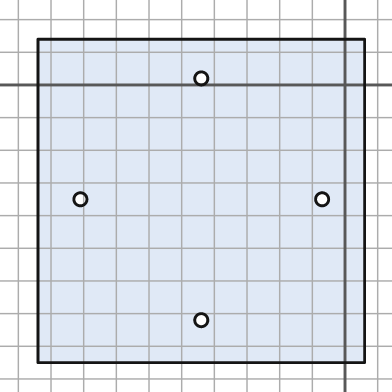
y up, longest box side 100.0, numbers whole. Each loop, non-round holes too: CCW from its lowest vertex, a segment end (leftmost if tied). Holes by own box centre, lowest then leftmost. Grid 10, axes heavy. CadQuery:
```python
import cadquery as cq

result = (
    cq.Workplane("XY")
    .moveTo(-94.0, -85.0)
    .lineTo(6.0, -85.0)
    .lineTo(6.0, 14.0)
    .lineTo(-94.0, 14.0)
    .close()
    .moveTo(-44.0, -72.0)
    .circle(2.0)
    .moveTo(-81.0, -35.0)
    .circle(2.0)
    .moveTo(-7.0, -35.0)
    .circle(2.0)
    .moveTo(-44.0, 2.0)
    .circle(2.0)
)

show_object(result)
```